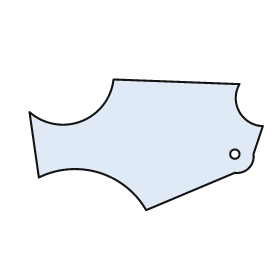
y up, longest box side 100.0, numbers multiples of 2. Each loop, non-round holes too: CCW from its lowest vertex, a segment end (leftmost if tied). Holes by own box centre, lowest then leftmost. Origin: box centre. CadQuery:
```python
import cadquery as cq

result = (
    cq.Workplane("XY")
    .moveTo(0.0, -28.0)
    .lineTo(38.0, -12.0)
    .threePointArc((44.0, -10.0), (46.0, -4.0))
    .lineTo(50.0, 8.0)
    .threePointArc((40.0, 14.0), (40.0, 26.0))
    .lineTo(-14.0, 28.0)
    .threePointArc((-28.0, 10.0), (-50.0, 14.0))
    .lineTo(-46.0, -14.0)
    .threePointArc((-20.0, -12.0), (0.0, -28.0))
    .close()
    .moveTo(38.0, -4.0)
    .circle(2.0)
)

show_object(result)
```